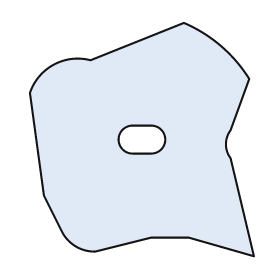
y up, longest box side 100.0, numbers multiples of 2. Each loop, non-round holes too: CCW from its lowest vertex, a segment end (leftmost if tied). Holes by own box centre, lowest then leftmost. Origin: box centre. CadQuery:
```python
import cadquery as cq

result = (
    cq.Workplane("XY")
    .moveTo(48.0, -50.0)
    .lineTo(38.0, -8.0)
    .threePointArc((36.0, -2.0), (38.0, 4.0))
    .lineTo(46.0, 26.0)
    .threePointArc((34.0, 40.0), (18.0, 50.0))
    .lineTo(-22.0, 34.0)
    .threePointArc((-38.0, 32.0), (-48.0, 20.0))
    .lineTo(-42.0, -24.0)
    .lineTo(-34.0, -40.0)
    .threePointArc((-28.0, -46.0), (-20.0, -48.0))
    .lineTo(4.0, -42.0)
    .lineTo(20.0, -42.0)
    .close()
    .moveTo(-4.0, -6.0)
    .lineTo(4.0, -6.0)
    .threePointArc((10.0, 0.0), (4.0, 6.0))
    .lineTo(-4.0, 6.0)
    .threePointArc((-10.0, 0.0), (-4.0, -6.0))
    .close()
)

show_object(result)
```